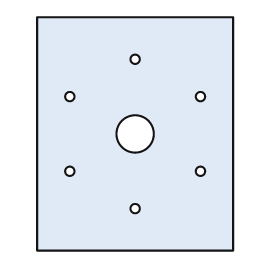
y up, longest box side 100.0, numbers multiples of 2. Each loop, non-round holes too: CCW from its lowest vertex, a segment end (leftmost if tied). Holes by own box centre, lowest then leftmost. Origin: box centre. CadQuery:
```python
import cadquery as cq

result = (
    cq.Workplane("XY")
    .moveTo(-42.0, -50.0)
    .lineTo(42.0, -50.0)
    .lineTo(42.0, 50.0)
    .lineTo(-42.0, 50.0)
    .close()
    .moveTo(0.0, -32.0)
    .circle(2.0)
    .moveTo(-28.0, -16.0)
    .circle(2.0)
    .moveTo(28.0, -16.0)
    .circle(2.0)
    .moveTo(0.0, 0.0)
    .circle(8.0)
    .moveTo(-28.0, 16.0)
    .circle(2.0)
    .moveTo(28.0, 16.0)
    .circle(2.0)
    .moveTo(0.0, 32.0)
    .circle(2.0)
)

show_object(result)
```